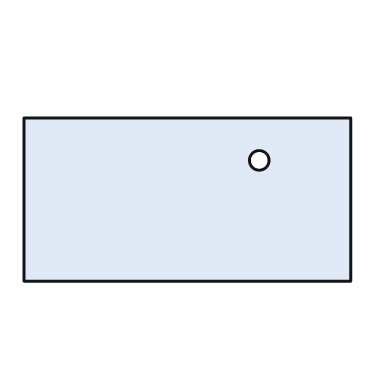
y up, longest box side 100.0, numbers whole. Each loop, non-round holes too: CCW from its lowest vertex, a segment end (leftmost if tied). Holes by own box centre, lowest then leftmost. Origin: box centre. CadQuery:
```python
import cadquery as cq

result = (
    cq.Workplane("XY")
    .moveTo(-50.0, -25.0)
    .lineTo(50.0, -25.0)
    .lineTo(50.0, 25.0)
    .lineTo(-50.0, 25.0)
    .close()
    .moveTo(22.0, 12.0)
    .circle(3.0)
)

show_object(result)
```